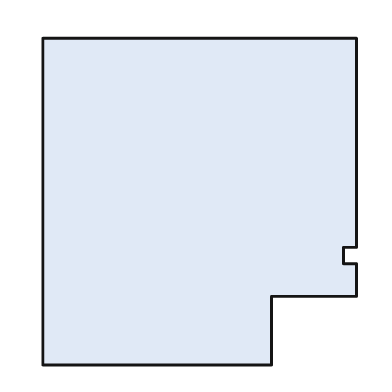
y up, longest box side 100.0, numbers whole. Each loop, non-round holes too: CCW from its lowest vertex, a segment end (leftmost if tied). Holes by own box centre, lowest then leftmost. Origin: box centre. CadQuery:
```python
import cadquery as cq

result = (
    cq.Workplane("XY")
    .moveTo(-48.0, -50.0)
    .lineTo(22.0, -50.0)
    .lineTo(22.0, -29.0)
    .lineTo(48.0, -29.0)
    .lineTo(48.0, -19.0)
    .lineTo(44.0, -19.0)
    .lineTo(44.0, -14.0)
    .lineTo(48.0, -14.0)
    .lineTo(48.0, 50.0)
    .lineTo(-48.0, 50.0)
    .close()
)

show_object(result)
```